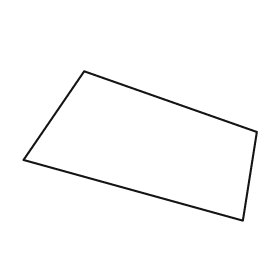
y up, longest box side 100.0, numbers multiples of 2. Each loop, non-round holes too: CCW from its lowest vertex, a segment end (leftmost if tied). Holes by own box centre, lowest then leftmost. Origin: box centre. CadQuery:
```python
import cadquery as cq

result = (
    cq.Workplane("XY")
    .moveTo(44.0, -32.0)
    .lineTo(50.0, 6.0)
    .lineTo(-24.0, 32.0)
    .lineTo(-50.0, -6.0)
    .close()
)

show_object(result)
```